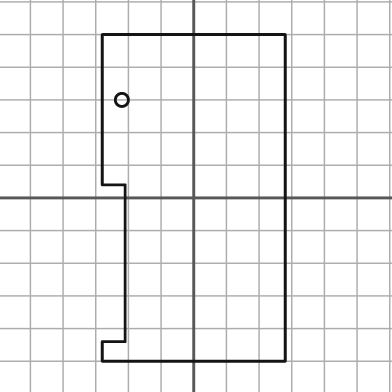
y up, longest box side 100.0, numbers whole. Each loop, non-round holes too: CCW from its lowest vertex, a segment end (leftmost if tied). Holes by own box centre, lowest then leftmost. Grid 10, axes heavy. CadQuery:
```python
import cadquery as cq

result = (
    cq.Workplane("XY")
    .moveTo(-28.0, -50.0)
    .lineTo(28.0, -50.0)
    .lineTo(28.0, 50.0)
    .lineTo(-28.0, 50.0)
    .lineTo(-28.0, 4.0)
    .lineTo(-21.0, 4.0)
    .lineTo(-21.0, -44.0)
    .lineTo(-28.0, -44.0)
    .close()
    .moveTo(-22.0, 30.0)
    .circle(2.0)
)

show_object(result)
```